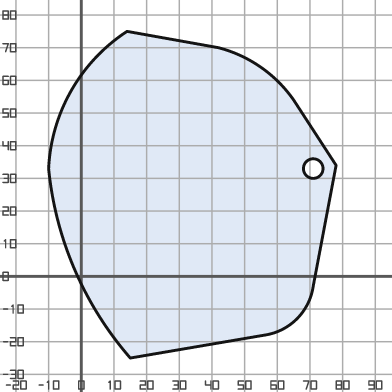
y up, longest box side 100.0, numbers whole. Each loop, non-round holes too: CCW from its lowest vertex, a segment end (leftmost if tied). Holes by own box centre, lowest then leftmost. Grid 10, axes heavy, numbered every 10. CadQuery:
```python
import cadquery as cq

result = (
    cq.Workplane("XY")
    .moveTo(15.0, -25.0)
    .lineTo(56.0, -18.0)
    .threePointArc((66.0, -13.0), (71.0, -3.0))
    .lineTo(78.0, 34.0)
    .lineTo(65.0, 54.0)
    .threePointArc((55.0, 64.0), (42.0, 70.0))
    .lineTo(14.0, 75.0)
    .threePointArc((-3.0, 57.0), (-10.0, 33.0))
    .threePointArc((-2.0, 2.0), (15.0, -25.0))
    .close()
    .moveTo(71.0, 33.0)
    .circle(3.0)
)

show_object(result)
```